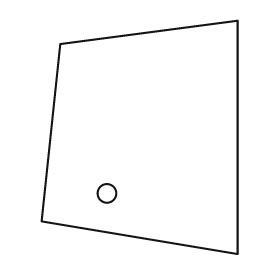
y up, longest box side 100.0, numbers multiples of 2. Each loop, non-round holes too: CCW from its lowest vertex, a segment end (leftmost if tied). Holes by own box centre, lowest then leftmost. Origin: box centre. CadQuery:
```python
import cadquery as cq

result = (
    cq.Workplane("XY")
    .moveTo(42.0, -50.0)
    .lineTo(42.0, 50.0)
    .lineTo(-34.0, 40.0)
    .lineTo(-42.0, -36.0)
    .close()
    .moveTo(-14.0, -24.0)
    .circle(4.0)
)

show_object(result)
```